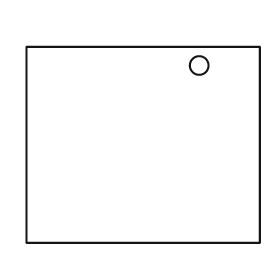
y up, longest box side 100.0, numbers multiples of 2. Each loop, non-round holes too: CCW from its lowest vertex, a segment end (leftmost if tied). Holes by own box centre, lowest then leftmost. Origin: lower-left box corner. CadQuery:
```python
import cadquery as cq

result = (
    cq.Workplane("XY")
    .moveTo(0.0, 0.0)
    .lineTo(100.0, 0.0)
    .lineTo(100.0, 84.0)
    .lineTo(0.0, 84.0)
    .close()
    .moveTo(74.0, 76.0)
    .circle(4.0)
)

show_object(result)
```